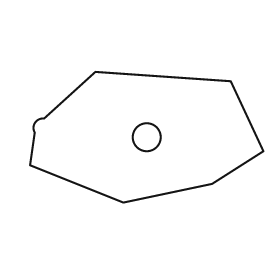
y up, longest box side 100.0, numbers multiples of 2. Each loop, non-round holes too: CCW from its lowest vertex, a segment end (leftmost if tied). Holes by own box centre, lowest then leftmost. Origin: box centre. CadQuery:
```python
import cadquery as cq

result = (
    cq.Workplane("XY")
    .moveTo(-10.0, -28.0)
    .lineTo(28.0, -20.0)
    .lineTo(50.0, -6.0)
    .lineTo(36.0, 24.0)
    .lineTo(-22.0, 28.0)
    .lineTo(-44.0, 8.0)
    .threePointArc((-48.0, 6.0), (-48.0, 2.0))
    .lineTo(-50.0, -12.0)
    .close()
    .moveTo(0.0, 0.0)
    .circle(6.0)
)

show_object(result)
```